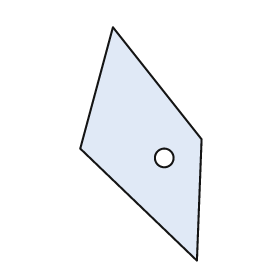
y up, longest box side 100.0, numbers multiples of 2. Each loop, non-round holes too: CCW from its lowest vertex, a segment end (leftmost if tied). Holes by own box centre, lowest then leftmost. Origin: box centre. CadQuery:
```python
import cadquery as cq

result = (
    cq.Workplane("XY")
    .moveTo(24.0, -50.0)
    .lineTo(26.0, 2.0)
    .lineTo(-12.0, 50.0)
    .lineTo(-26.0, -2.0)
    .close()
    .moveTo(10.0, -6.0)
    .circle(4.0)
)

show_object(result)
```